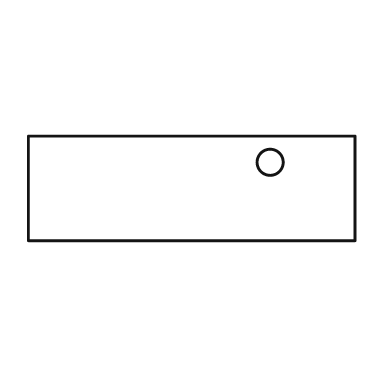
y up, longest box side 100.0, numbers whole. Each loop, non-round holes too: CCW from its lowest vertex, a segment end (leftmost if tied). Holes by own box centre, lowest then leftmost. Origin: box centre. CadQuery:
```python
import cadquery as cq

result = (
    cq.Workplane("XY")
    .moveTo(-50.0, -16.0)
    .lineTo(50.0, -16.0)
    .lineTo(50.0, 16.0)
    .lineTo(-50.0, 16.0)
    .close()
    .moveTo(24.0, 8.0)
    .circle(4.0)
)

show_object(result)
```